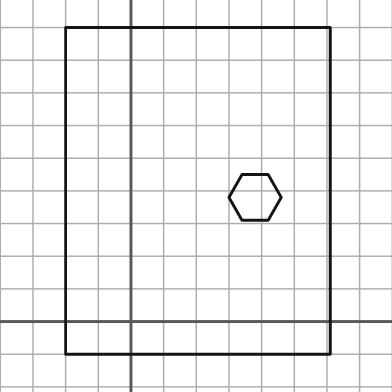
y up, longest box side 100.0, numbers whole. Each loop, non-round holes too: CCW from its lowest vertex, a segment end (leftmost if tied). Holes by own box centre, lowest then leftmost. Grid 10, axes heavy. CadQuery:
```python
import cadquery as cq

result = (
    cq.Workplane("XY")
    .moveTo(-20.0, -10.0)
    .lineTo(61.0, -10.0)
    .lineTo(61.0, 90.0)
    .lineTo(-20.0, 90.0)
    .close()
    .moveTo(34.0, 31.0)
    .lineTo(42.0, 31.0)
    .lineTo(46.0, 38.0)
    .lineTo(42.0, 45.0)
    .lineTo(34.0, 45.0)
    .lineTo(30.0, 38.0)
    .close()
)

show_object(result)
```